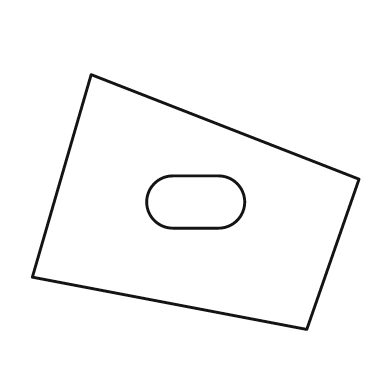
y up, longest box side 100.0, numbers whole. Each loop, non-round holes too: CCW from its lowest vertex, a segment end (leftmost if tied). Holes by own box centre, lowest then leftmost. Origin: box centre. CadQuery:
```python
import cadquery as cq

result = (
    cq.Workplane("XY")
    .moveTo(34.0, -39.0)
    .lineTo(50.0, 7.0)
    .lineTo(-32.0, 39.0)
    .lineTo(-50.0, -23.0)
    .close()
    .moveTo(-7.0, -8.0)
    .lineTo(7.0, -8.0)
    .threePointArc((15.0, 0.0), (7.0, 8.0))
    .lineTo(-7.0, 8.0)
    .threePointArc((-15.0, 0.0), (-7.0, -8.0))
    .close()
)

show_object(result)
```